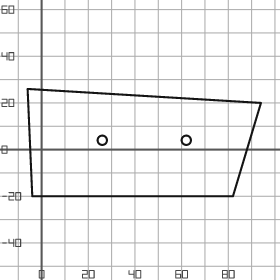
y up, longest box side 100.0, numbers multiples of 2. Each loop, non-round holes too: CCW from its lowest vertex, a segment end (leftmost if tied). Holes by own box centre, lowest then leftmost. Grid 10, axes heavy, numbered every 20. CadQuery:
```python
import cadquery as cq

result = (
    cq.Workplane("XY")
    .moveTo(-4.0, -20.0)
    .lineTo(82.0, -20.0)
    .lineTo(94.0, 20.0)
    .lineTo(-6.0, 26.0)
    .close()
    .moveTo(26.0, 4.0)
    .circle(2.0)
    .moveTo(62.0, 4.0)
    .circle(2.0)
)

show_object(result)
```